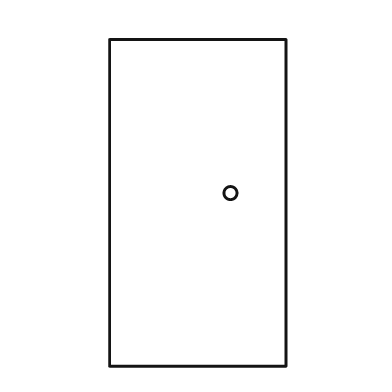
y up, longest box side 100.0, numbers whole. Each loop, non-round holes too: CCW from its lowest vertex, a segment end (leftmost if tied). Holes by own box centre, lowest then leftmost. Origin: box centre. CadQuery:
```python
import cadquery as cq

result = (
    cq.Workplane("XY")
    .moveTo(-27.0, -50.0)
    .lineTo(27.0, -50.0)
    .lineTo(27.0, 50.0)
    .lineTo(-27.0, 50.0)
    .close()
    .moveTo(10.0, 3.0)
    .circle(2.0)
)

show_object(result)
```